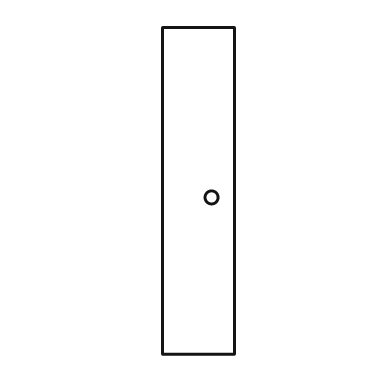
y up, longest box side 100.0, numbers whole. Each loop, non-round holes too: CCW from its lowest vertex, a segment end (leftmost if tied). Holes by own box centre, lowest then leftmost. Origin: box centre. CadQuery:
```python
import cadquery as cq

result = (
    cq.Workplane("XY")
    .moveTo(-11.0, -50.0)
    .lineTo(11.0, -50.0)
    .lineTo(11.0, 50.0)
    .lineTo(-11.0, 50.0)
    .close()
    .moveTo(4.0, -2.0)
    .circle(2.0)
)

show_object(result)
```